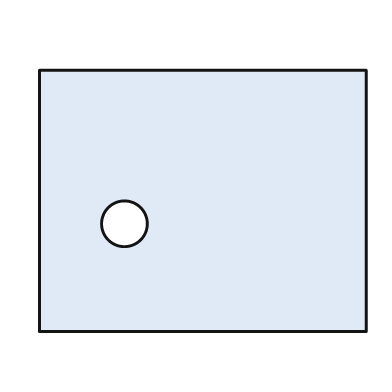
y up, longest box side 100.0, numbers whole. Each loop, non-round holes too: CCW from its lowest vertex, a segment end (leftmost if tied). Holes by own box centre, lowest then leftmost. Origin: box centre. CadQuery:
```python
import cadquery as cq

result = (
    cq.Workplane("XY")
    .moveTo(-50.0, -40.0)
    .lineTo(50.0, -40.0)
    .lineTo(50.0, 40.0)
    .lineTo(-50.0, 40.0)
    .close()
    .moveTo(-24.0, -7.0)
    .circle(7.0)
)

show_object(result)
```